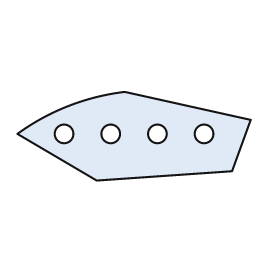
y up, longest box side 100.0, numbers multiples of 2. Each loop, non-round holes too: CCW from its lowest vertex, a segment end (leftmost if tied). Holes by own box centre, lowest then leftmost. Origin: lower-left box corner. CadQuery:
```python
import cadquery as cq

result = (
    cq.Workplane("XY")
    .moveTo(34.0, 0.0)
    .lineTo(92.0, 4.0)
    .lineTo(100.0, 26.0)
    .lineTo(46.0, 38.0)
    .threePointArc((22.0, 32.0), (0.0, 20.0))
    .close()
    .moveTo(20.0, 20.0)
    .circle(4.0)
    .moveTo(40.0, 20.0)
    .circle(4.0)
    .moveTo(60.0, 20.0)
    .circle(4.0)
    .moveTo(80.0, 20.0)
    .circle(4.0)
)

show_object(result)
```